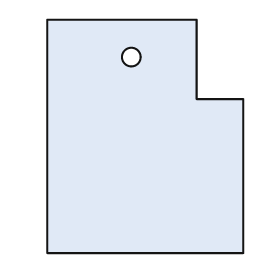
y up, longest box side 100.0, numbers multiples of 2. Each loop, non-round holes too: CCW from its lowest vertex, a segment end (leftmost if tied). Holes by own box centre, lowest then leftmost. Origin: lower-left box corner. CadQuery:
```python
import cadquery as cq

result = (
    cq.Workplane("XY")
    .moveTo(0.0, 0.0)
    .lineTo(84.0, 0.0)
    .lineTo(84.0, 66.0)
    .lineTo(64.0, 66.0)
    .lineTo(64.0, 100.0)
    .lineTo(0.0, 100.0)
    .close()
    .moveTo(36.0, 84.0)
    .circle(4.0)
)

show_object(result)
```